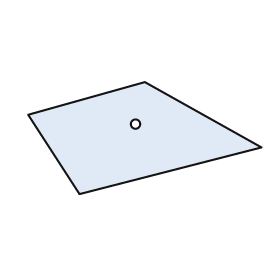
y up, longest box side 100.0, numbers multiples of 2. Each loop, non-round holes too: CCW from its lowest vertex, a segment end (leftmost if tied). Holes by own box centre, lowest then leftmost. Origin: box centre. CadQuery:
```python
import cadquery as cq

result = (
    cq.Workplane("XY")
    .moveTo(-28.0, -24.0)
    .lineTo(50.0, -4.0)
    .lineTo(0.0, 24.0)
    .lineTo(-50.0, 10.0)
    .close()
    .moveTo(-4.0, 6.0)
    .circle(2.0)
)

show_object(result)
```